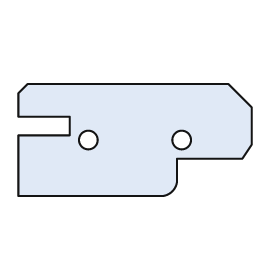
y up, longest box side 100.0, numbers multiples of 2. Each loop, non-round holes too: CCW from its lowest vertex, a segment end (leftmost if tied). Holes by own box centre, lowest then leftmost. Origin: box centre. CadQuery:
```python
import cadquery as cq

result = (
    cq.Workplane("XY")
    .moveTo(-50.0, -24.0)
    .lineTo(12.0, -24.0)
    .threePointArc((16.0, -22.0), (18.0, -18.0))
    .lineTo(18.0, -8.0)
    .lineTo(46.0, -8.0)
    .lineTo(50.0, -2.0)
    .lineTo(50.0, 14.0)
    .lineTo(40.0, 24.0)
    .lineTo(-46.0, 24.0)
    .lineTo(-50.0, 20.0)
    .lineTo(-50.0, 10.0)
    .lineTo(-28.0, 10.0)
    .lineTo(-28.0, 2.0)
    .lineTo(-50.0, 2.0)
    .close()
    .moveTo(-20.0, 0.0)
    .circle(4.0)
    .moveTo(20.0, 0.0)
    .circle(4.0)
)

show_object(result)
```